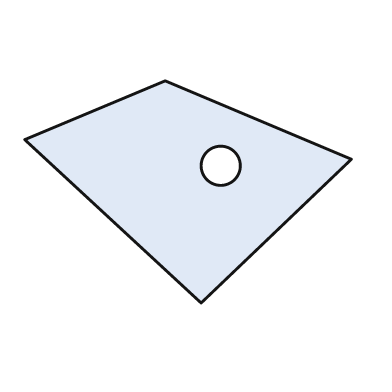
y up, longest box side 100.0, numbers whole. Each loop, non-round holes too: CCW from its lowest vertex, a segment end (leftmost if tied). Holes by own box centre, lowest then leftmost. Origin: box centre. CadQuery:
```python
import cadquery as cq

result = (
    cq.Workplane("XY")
    .moveTo(4.0, -34.0)
    .lineTo(50.0, 10.0)
    .lineTo(-7.0, 34.0)
    .lineTo(-50.0, 16.0)
    .close()
    .moveTo(10.0, 8.0)
    .circle(6.0)
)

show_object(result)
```